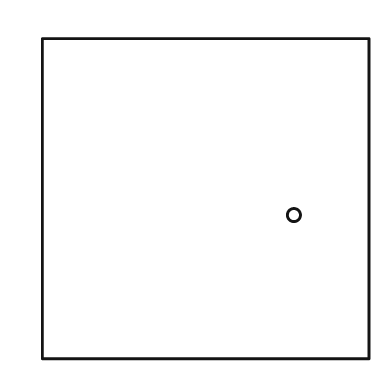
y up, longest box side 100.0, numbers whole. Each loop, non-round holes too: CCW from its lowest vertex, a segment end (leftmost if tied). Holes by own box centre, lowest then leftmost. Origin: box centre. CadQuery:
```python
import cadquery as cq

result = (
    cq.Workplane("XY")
    .moveTo(-50.0, -49.0)
    .lineTo(50.0, -49.0)
    .lineTo(50.0, 49.0)
    .lineTo(-50.0, 49.0)
    .close()
    .moveTo(27.0, -5.0)
    .circle(2.0)
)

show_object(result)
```